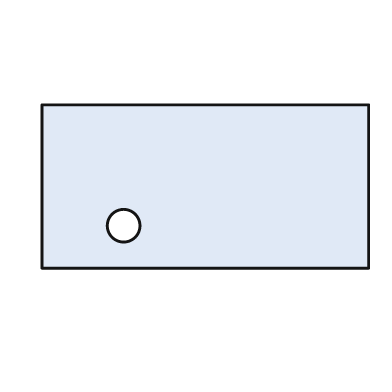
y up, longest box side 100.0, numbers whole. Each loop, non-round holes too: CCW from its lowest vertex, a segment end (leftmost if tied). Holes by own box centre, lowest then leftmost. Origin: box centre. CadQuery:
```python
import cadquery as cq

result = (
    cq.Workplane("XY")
    .moveTo(-50.0, -25.0)
    .lineTo(50.0, -25.0)
    .lineTo(50.0, 25.0)
    .lineTo(-50.0, 25.0)
    .close()
    .moveTo(-25.0, -12.0)
    .circle(5.0)
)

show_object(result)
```